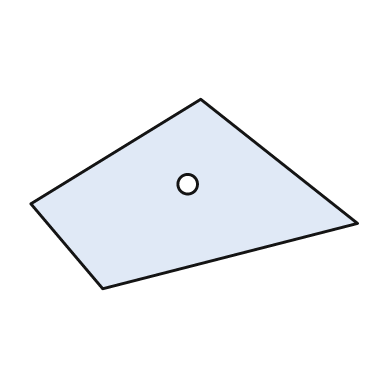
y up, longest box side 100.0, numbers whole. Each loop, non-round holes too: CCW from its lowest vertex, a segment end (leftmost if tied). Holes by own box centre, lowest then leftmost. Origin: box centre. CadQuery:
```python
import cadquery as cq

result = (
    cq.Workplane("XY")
    .moveTo(-28.0, -29.0)
    .lineTo(50.0, -9.0)
    .lineTo(2.0, 29.0)
    .lineTo(-50.0, -3.0)
    .close()
    .moveTo(-2.0, 3.0)
    .circle(3.0)
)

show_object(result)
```